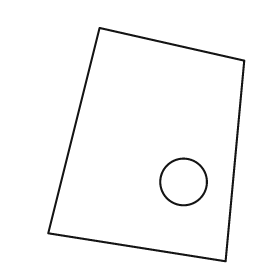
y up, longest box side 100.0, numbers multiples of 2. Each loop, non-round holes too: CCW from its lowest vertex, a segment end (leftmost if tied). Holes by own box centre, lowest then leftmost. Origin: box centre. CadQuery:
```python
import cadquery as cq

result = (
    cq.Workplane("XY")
    .moveTo(34.0, -50.0)
    .lineTo(42.0, 36.0)
    .lineTo(-20.0, 50.0)
    .lineTo(-42.0, -38.0)
    .close()
    .moveTo(16.0, -16.0)
    .circle(10.0)
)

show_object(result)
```